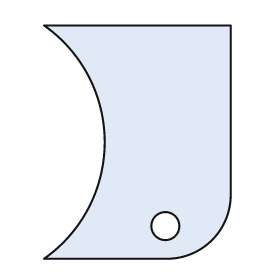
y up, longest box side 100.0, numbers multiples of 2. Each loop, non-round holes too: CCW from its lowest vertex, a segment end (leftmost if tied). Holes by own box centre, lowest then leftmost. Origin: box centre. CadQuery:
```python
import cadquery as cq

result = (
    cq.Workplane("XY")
    .moveTo(-40.0, -50.0)
    .lineTo(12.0, -50.0)
    .threePointArc((32.0, -42.0), (40.0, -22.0))
    .lineTo(40.0, 50.0)
    .lineTo(-40.0, 50.0)
    .threePointArc((-14.0, 0.0), (-40.0, -50.0))
    .close()
    .moveTo(12.0, -36.0)
    .circle(6.0)
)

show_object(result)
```